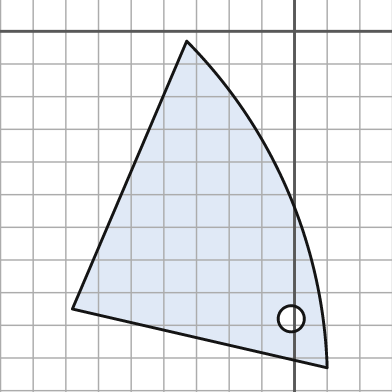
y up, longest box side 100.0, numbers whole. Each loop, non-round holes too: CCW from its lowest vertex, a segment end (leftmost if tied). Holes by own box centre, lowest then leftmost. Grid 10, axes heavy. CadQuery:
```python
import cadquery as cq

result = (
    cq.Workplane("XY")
    .moveTo(10.0, -103.0)
    .threePointArc((-2.0, -49.0), (-33.0, -3.0))
    .lineTo(-68.0, -85.0)
    .close()
    .moveTo(-1.0, -88.0)
    .circle(4.0)
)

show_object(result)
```